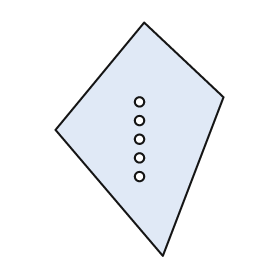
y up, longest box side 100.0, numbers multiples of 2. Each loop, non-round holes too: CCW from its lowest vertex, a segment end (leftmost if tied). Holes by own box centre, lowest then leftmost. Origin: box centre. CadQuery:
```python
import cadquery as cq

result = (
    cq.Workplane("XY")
    .moveTo(10.0, -50.0)
    .lineTo(36.0, 18.0)
    .lineTo(2.0, 50.0)
    .lineTo(-36.0, 4.0)
    .close()
    .moveTo(0.0, -16.0)
    .circle(2.0)
    .moveTo(0.0, -8.0)
    .circle(2.0)
    .moveTo(0.0, 0.0)
    .circle(2.0)
    .moveTo(0.0, 8.0)
    .circle(2.0)
    .moveTo(0.0, 16.0)
    .circle(2.0)
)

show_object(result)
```